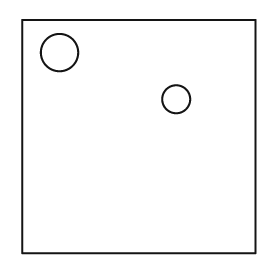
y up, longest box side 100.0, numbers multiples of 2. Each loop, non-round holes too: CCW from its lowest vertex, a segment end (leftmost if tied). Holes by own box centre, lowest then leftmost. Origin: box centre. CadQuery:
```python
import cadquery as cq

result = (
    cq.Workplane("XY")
    .moveTo(-50.0, -50.0)
    .lineTo(50.0, -50.0)
    .lineTo(50.0, 50.0)
    .lineTo(-50.0, 50.0)
    .close()
    .moveTo(16.0, 16.0)
    .circle(6.0)
    .moveTo(-34.0, 36.0)
    .circle(8.0)
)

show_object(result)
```